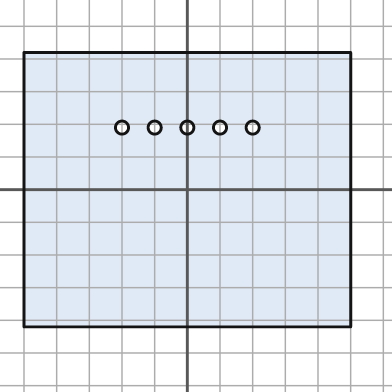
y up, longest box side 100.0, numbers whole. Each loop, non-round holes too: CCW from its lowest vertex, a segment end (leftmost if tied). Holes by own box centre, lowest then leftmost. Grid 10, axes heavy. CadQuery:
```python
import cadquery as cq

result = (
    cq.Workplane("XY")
    .moveTo(-50.0, -42.0)
    .lineTo(50.0, -42.0)
    .lineTo(50.0, 42.0)
    .lineTo(-50.0, 42.0)
    .close()
    .moveTo(-20.0, 19.0)
    .circle(2.0)
    .moveTo(-10.0, 19.0)
    .circle(2.0)
    .moveTo(0.0, 19.0)
    .circle(2.0)
    .moveTo(10.0, 19.0)
    .circle(2.0)
    .moveTo(20.0, 19.0)
    .circle(2.0)
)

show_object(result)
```